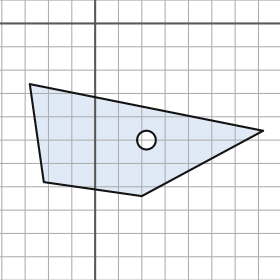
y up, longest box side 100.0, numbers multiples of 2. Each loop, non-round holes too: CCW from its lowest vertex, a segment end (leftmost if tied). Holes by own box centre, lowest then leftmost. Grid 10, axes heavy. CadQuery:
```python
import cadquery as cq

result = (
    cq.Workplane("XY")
    .moveTo(20.0, -74.0)
    .lineTo(72.0, -46.0)
    .lineTo(-28.0, -26.0)
    .lineTo(-22.0, -68.0)
    .close()
    .moveTo(22.0, -50.0)
    .circle(4.0)
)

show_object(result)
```